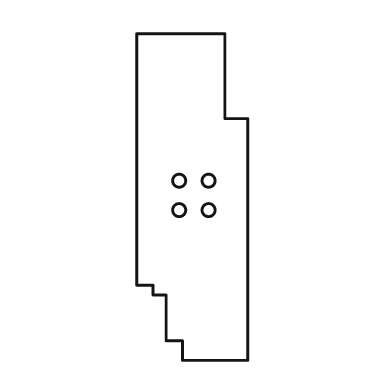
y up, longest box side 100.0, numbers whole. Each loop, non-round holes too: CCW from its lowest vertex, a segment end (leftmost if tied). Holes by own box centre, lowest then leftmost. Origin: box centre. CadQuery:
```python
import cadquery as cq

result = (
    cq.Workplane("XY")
    .moveTo(-3.0, -50.0)
    .lineTo(17.0, -50.0)
    .lineTo(17.0, 24.0)
    .lineTo(10.0, 24.0)
    .lineTo(10.0, 50.0)
    .lineTo(-17.0, 50.0)
    .lineTo(-17.0, -27.0)
    .lineTo(-12.0, -27.0)
    .lineTo(-12.0, -30.0)
    .lineTo(-8.0, -30.0)
    .lineTo(-8.0, -44.0)
    .lineTo(-3.0, -44.0)
    .close()
    .moveTo(-4.0, -4.0)
    .circle(2.0)
    .moveTo(5.0, -4.0)
    .circle(2.0)
    .moveTo(-4.0, 5.0)
    .circle(2.0)
    .moveTo(5.0, 5.0)
    .circle(2.0)
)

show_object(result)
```